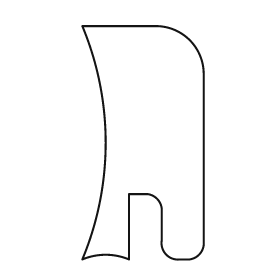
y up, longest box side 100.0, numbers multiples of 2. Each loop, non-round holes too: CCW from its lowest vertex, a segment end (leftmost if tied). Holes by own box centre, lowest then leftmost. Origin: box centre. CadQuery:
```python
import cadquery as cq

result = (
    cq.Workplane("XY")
    .moveTo(-26.0, -50.0)
    .threePointArc((-16.0, -48.0), (-6.0, -50.0))
    .lineTo(-6.0, -22.0)
    .lineTo(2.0, -22.0)
    .threePointArc((6.0, -24.0), (8.0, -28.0))
    .lineTo(8.0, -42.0)
    .threePointArc((10.0, -48.0), (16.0, -50.0))
    .lineTo(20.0, -50.0)
    .threePointArc((24.0, -48.0), (26.0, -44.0))
    .lineTo(26.0, 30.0)
    .threePointArc((20.0, 44.0), (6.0, 50.0))
    .lineTo(-26.0, 50.0)
    .threePointArc((-16.0, 0.0), (-26.0, -50.0))
    .close()
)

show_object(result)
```